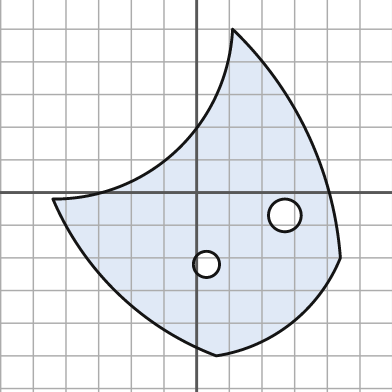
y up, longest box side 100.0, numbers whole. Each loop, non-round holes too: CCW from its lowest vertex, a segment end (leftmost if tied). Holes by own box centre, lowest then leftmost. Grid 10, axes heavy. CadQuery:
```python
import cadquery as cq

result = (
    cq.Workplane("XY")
    .moveTo(6.0, -50.0)
    .threePointArc((29.0, -40.0), (44.0, -20.0))
    .threePointArc((34.0, 18.0), (11.0, 50.0))
    .threePointArc((-6.0, 13.0), (-44.0, -2.0))
    .threePointArc((-24.0, -31.0), (6.0, -50.0))
    .close()
    .moveTo(3.0, -22.0)
    .circle(4.0)
    .moveTo(27.0, -7.0)
    .circle(5.0)
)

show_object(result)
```